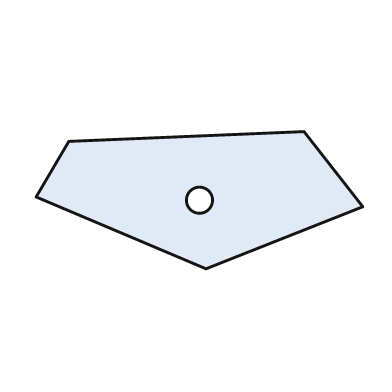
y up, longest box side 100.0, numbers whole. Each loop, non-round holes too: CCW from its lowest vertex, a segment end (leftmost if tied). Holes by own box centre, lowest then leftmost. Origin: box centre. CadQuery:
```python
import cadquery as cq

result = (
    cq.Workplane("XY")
    .moveTo(2.0, -21.0)
    .lineTo(50.0, -2.0)
    .lineTo(32.0, 21.0)
    .lineTo(-40.0, 18.0)
    .lineTo(-50.0, 1.0)
    .close()
    .moveTo(0.0, 0.0)
    .circle(4.0)
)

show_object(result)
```